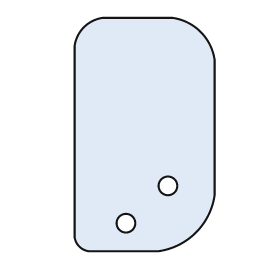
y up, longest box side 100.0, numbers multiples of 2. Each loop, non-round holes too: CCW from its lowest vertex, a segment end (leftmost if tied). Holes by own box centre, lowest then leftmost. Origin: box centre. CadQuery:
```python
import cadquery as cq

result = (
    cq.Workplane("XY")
    .moveTo(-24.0, -50.0)
    .lineTo(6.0, -50.0)
    .threePointArc((22.0, -42.0), (30.0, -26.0))
    .lineTo(30.0, 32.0)
    .threePointArc((24.0, 44.0), (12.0, 50.0))
    .lineTo(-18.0, 50.0)
    .threePointArc((-26.0, 46.0), (-30.0, 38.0))
    .lineTo(-30.0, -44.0)
    .threePointArc((-28.0, -48.0), (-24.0, -50.0))
    .close()
    .moveTo(-8.0, -38.0)
    .circle(4.0)
    .moveTo(10.0, -22.0)
    .circle(4.0)
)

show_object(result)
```